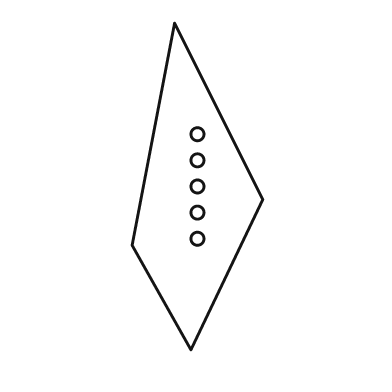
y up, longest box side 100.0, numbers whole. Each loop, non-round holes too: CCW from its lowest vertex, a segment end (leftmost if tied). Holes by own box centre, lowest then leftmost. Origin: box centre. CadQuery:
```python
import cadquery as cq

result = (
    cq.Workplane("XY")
    .moveTo(-2.0, -50.0)
    .lineTo(20.0, -4.0)
    .lineTo(-7.0, 50.0)
    .lineTo(-20.0, -18.0)
    .close()
    .moveTo(0.0, -16.0)
    .circle(2.0)
    .moveTo(0.0, -8.0)
    .circle(2.0)
    .moveTo(0.0, 0.0)
    .circle(2.0)
    .moveTo(0.0, 8.0)
    .circle(2.0)
    .moveTo(0.0, 16.0)
    .circle(2.0)
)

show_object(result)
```